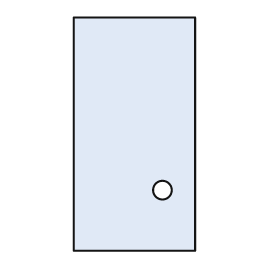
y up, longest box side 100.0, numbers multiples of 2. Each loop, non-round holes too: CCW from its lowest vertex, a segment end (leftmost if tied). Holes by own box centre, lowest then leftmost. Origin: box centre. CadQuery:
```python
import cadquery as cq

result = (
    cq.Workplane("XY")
    .moveTo(-26.0, -50.0)
    .lineTo(26.0, -50.0)
    .lineTo(26.0, 50.0)
    .lineTo(-26.0, 50.0)
    .close()
    .moveTo(12.0, -24.0)
    .circle(4.0)
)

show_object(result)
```